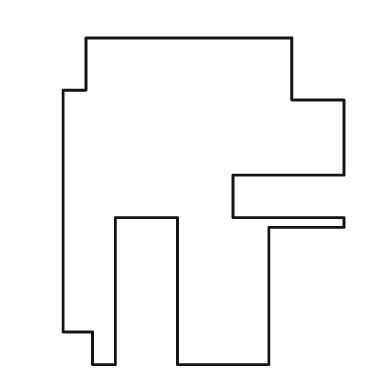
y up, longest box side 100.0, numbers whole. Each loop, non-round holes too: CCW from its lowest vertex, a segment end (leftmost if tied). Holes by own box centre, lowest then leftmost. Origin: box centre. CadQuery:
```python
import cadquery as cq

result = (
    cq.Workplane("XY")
    .moveTo(-34.0, -50.0)
    .lineTo(-27.0, -50.0)
    .lineTo(-27.0, -5.0)
    .lineTo(-8.0, -5.0)
    .lineTo(-8.0, -50.0)
    .lineTo(20.0, -50.0)
    .lineTo(20.0, -8.0)
    .lineTo(43.0, -8.0)
    .lineTo(43.0, -5.0)
    .lineTo(9.0, -5.0)
    .lineTo(9.0, 8.0)
    .lineTo(43.0, 8.0)
    .lineTo(43.0, 31.0)
    .lineTo(27.0, 31.0)
    .lineTo(27.0, 50.0)
    .lineTo(-36.0, 50.0)
    .lineTo(-36.0, 34.0)
    .lineTo(-43.0, 34.0)
    .lineTo(-43.0, -40.0)
    .lineTo(-34.0, -40.0)
    .close()
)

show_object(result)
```